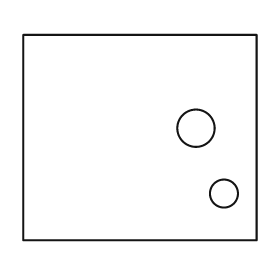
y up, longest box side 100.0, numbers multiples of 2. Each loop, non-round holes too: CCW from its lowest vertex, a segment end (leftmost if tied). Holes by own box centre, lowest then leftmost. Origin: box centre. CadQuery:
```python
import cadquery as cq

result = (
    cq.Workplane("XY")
    .moveTo(-50.0, -44.0)
    .lineTo(50.0, -44.0)
    .lineTo(50.0, 44.0)
    .lineTo(-50.0, 44.0)
    .close()
    .moveTo(36.0, -24.0)
    .circle(6.0)
    .moveTo(24.0, 4.0)
    .circle(8.0)
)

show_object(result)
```